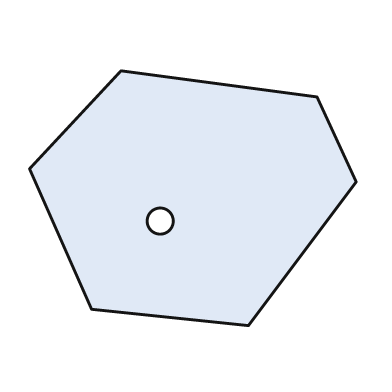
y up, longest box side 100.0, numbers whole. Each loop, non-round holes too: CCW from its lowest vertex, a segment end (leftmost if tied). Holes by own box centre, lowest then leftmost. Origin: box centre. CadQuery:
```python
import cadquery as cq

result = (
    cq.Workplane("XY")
    .moveTo(17.0, -39.0)
    .lineTo(50.0, 5.0)
    .lineTo(38.0, 31.0)
    .lineTo(-22.0, 39.0)
    .lineTo(-50.0, 9.0)
    .lineTo(-31.0, -34.0)
    .close()
    .moveTo(-10.0, -7.0)
    .circle(4.0)
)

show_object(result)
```